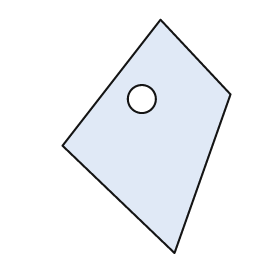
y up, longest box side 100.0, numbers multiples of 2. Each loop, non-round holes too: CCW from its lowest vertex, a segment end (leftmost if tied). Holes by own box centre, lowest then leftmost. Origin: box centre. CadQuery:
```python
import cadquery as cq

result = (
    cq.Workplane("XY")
    .moveTo(12.0, -50.0)
    .lineTo(36.0, 18.0)
    .lineTo(6.0, 50.0)
    .lineTo(-36.0, -4.0)
    .close()
    .moveTo(-2.0, 16.0)
    .circle(6.0)
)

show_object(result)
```